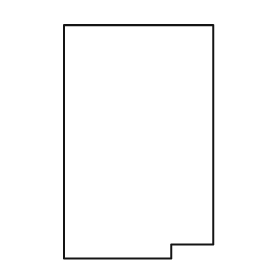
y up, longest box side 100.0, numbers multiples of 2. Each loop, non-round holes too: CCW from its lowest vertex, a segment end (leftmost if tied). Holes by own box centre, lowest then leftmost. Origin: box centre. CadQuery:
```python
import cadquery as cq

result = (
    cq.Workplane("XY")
    .moveTo(-32.0, -50.0)
    .lineTo(14.0, -50.0)
    .lineTo(14.0, -44.0)
    .lineTo(32.0, -44.0)
    .lineTo(32.0, 50.0)
    .lineTo(-32.0, 50.0)
    .close()
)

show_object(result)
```